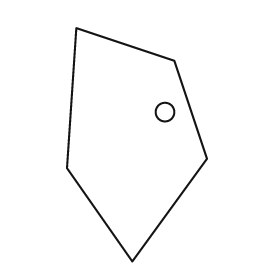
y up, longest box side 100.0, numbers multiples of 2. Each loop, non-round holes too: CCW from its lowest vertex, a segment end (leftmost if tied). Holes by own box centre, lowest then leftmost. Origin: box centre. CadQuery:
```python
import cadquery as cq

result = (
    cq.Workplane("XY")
    .moveTo(-2.0, -50.0)
    .lineTo(30.0, -6.0)
    .lineTo(16.0, 36.0)
    .lineTo(-26.0, 50.0)
    .lineTo(-30.0, -10.0)
    .close()
    .moveTo(12.0, 14.0)
    .circle(4.0)
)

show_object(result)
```